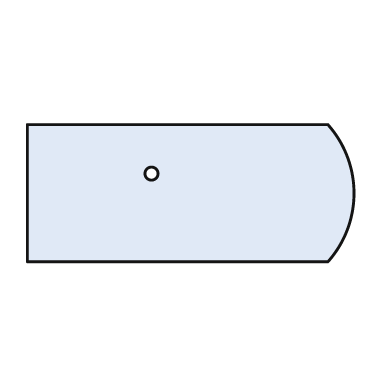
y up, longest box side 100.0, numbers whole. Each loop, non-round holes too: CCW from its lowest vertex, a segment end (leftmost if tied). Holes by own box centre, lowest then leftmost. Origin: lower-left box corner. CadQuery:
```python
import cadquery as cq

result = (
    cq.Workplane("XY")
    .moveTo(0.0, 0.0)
    .lineTo(92.0, 0.0)
    .threePointArc((100.0, 21.0), (92.0, 42.0))
    .lineTo(0.0, 42.0)
    .close()
    .moveTo(38.0, 27.0)
    .circle(2.0)
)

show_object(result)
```